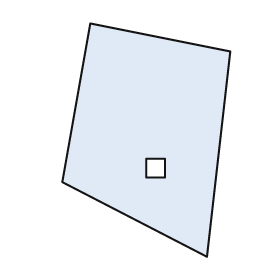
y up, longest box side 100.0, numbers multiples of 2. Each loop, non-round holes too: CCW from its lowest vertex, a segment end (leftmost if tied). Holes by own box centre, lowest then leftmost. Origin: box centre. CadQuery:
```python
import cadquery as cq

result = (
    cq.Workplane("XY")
    .moveTo(26.0, -50.0)
    .lineTo(36.0, 38.0)
    .lineTo(-24.0, 50.0)
    .lineTo(-36.0, -18.0)
    .close()
    .moveTo(0.0, -16.0)
    .lineTo(8.0, -16.0)
    .lineTo(8.0, -8.0)
    .lineTo(0.0, -8.0)
    .close()
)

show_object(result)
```